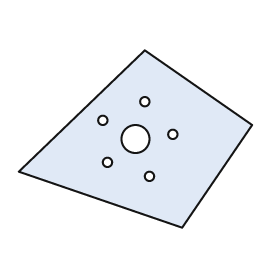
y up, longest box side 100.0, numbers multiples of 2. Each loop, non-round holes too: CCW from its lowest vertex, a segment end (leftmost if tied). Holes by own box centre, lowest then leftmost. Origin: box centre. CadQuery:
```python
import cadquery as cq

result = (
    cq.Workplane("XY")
    .moveTo(20.0, -38.0)
    .lineTo(50.0, 6.0)
    .lineTo(4.0, 38.0)
    .lineTo(-50.0, -14.0)
    .close()
    .moveTo(6.0, -16.0)
    .circle(2.0)
    .moveTo(-12.0, -10.0)
    .circle(2.0)
    .moveTo(0.0, 0.0)
    .circle(6.0)
    .moveTo(16.0, 2.0)
    .circle(2.0)
    .moveTo(-14.0, 8.0)
    .circle(2.0)
    .moveTo(4.0, 16.0)
    .circle(2.0)
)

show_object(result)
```